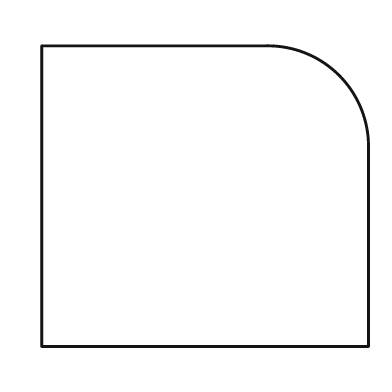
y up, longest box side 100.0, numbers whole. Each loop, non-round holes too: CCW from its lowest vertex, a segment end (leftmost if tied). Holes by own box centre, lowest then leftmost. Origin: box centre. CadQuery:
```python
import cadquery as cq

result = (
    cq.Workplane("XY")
    .moveTo(-50.0, -46.0)
    .lineTo(50.0, -46.0)
    .lineTo(50.0, 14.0)
    .threePointArc((41.0, 37.0), (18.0, 46.0))
    .lineTo(-50.0, 46.0)
    .close()
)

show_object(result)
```